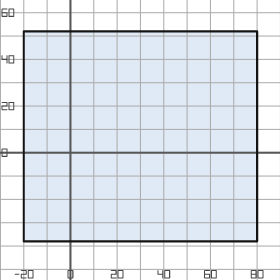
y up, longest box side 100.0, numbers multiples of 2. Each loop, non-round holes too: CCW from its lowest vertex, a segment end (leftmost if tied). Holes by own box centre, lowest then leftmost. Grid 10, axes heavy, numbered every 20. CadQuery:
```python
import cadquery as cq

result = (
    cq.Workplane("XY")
    .moveTo(-20.0, -38.0)
    .lineTo(80.0, -38.0)
    .lineTo(80.0, 52.0)
    .lineTo(-20.0, 52.0)
    .close()
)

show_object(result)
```